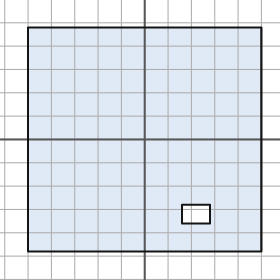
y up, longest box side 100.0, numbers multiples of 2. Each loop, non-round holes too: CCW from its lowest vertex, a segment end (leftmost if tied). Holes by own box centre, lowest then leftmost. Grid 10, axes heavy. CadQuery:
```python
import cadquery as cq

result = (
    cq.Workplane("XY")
    .moveTo(-50.0, -48.0)
    .lineTo(50.0, -48.0)
    .lineTo(50.0, 48.0)
    .lineTo(-50.0, 48.0)
    .close()
    .moveTo(16.0, -36.0)
    .lineTo(28.0, -36.0)
    .lineTo(28.0, -28.0)
    .lineTo(16.0, -28.0)
    .close()
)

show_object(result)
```